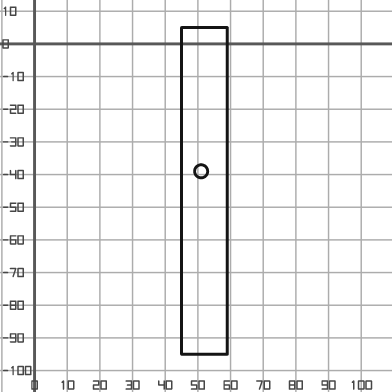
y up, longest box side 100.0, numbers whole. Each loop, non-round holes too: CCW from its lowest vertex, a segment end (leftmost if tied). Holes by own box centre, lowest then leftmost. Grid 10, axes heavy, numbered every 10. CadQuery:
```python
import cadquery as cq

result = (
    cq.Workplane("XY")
    .moveTo(45.0, -95.0)
    .lineTo(59.0, -95.0)
    .lineTo(59.0, 5.0)
    .lineTo(45.0, 5.0)
    .close()
    .moveTo(51.0, -39.0)
    .circle(2.0)
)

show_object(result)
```